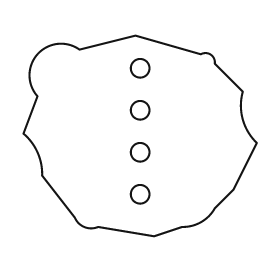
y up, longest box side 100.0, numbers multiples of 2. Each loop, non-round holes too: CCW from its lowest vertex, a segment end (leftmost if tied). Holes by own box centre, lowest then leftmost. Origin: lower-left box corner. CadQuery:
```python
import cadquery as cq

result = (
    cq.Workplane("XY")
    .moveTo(56.0, 0.0)
    .lineTo(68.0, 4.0)
    .threePointArc((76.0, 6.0), (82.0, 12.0))
    .lineTo(90.0, 20.0)
    .lineTo(100.0, 40.0)
    .threePointArc((94.0, 50.0), (94.0, 62.0))
    .lineTo(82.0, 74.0)
    .threePointArc((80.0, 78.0), (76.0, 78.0))
    .lineTo(48.0, 86.0)
    .lineTo(24.0, 80.0)
    .threePointArc((6.0, 78.0), (6.0, 60.0))
    .lineTo(0.0, 44.0)
    .threePointArc((6.0, 36.0), (8.0, 26.0))
    .lineTo(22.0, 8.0)
    .threePointArc((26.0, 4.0), (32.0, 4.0))
    .close()
    .moveTo(50.0, 18.0)
    .circle(4.0)
    .moveTo(50.0, 36.0)
    .circle(4.0)
    .moveTo(50.0, 54.0)
    .circle(4.0)
    .moveTo(50.0, 72.0)
    .circle(4.0)
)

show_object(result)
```